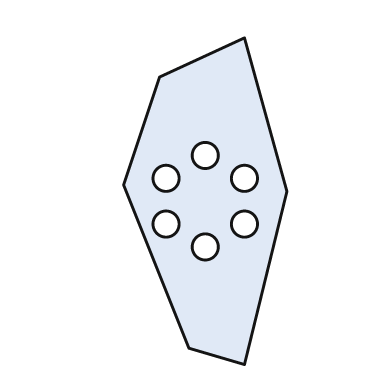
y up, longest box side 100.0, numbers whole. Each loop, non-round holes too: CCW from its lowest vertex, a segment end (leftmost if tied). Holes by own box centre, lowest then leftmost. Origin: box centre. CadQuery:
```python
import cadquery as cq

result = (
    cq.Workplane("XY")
    .moveTo(12.0, -50.0)
    .lineTo(25.0, 3.0)
    .lineTo(12.0, 50.0)
    .lineTo(-14.0, 38.0)
    .lineTo(-25.0, 5.0)
    .lineTo(-5.0, -45.0)
    .close()
    .moveTo(0.0, -14.0)
    .circle(4.0)
    .moveTo(-12.0, -7.0)
    .circle(4.0)
    .moveTo(12.0, -7.0)
    .circle(4.0)
    .moveTo(-12.0, 7.0)
    .circle(4.0)
    .moveTo(12.0, 7.0)
    .circle(4.0)
    .moveTo(0.0, 14.0)
    .circle(4.0)
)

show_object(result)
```